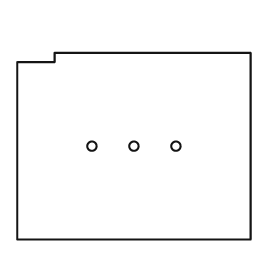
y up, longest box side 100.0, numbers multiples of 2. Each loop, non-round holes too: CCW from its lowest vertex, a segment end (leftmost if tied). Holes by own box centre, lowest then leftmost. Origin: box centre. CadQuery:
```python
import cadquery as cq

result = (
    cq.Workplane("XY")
    .moveTo(-50.0, -40.0)
    .lineTo(50.0, -40.0)
    .lineTo(50.0, 40.0)
    .lineTo(-34.0, 40.0)
    .lineTo(-34.0, 36.0)
    .lineTo(-50.0, 36.0)
    .close()
    .moveTo(-18.0, 0.0)
    .circle(2.0)
    .moveTo(0.0, 0.0)
    .circle(2.0)
    .moveTo(18.0, 0.0)
    .circle(2.0)
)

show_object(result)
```